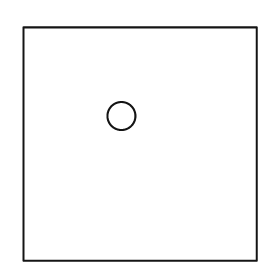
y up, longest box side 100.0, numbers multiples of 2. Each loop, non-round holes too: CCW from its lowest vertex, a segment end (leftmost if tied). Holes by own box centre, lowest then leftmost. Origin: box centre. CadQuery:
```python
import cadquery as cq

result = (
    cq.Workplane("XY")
    .moveTo(-50.0, -50.0)
    .lineTo(50.0, -50.0)
    .lineTo(50.0, 50.0)
    .lineTo(-50.0, 50.0)
    .close()
    .moveTo(-8.0, 12.0)
    .circle(6.0)
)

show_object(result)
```